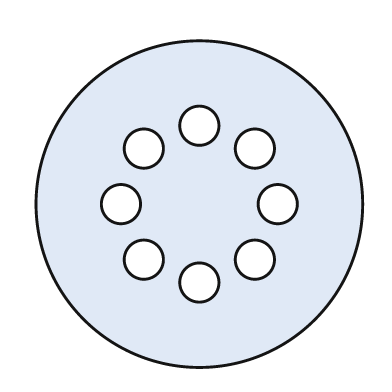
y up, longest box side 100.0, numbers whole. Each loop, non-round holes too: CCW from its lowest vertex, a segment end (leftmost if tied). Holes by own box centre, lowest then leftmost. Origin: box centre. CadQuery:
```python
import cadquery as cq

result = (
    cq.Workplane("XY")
    .moveTo(0.0, 0.0)
    .circle(50.0)
    .moveTo(0.0, -24.0)
    .circle(6.0)
    .moveTo(-17.0, -17.0)
    .circle(6.0)
    .moveTo(17.0, -17.0)
    .circle(6.0)
    .moveTo(-24.0, 0.0)
    .circle(6.0)
    .moveTo(24.0, 0.0)
    .circle(6.0)
    .moveTo(-17.0, 17.0)
    .circle(6.0)
    .moveTo(17.0, 17.0)
    .circle(6.0)
    .moveTo(0.0, 24.0)
    .circle(6.0)
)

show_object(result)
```